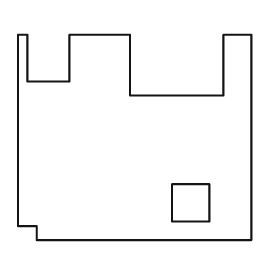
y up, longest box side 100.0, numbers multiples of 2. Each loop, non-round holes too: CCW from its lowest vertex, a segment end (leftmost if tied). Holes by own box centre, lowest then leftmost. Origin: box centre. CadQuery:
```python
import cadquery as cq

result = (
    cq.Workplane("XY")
    .moveTo(-42.0, -44.0)
    .lineTo(50.0, -44.0)
    .lineTo(50.0, 44.0)
    .lineTo(38.0, 44.0)
    .lineTo(38.0, 18.0)
    .lineTo(-2.0, 18.0)
    .lineTo(-2.0, 44.0)
    .lineTo(-28.0, 44.0)
    .lineTo(-28.0, 24.0)
    .lineTo(-46.0, 24.0)
    .lineTo(-46.0, 44.0)
    .lineTo(-50.0, 44.0)
    .lineTo(-50.0, -38.0)
    .lineTo(-42.0, -38.0)
    .close()
    .moveTo(16.0, -36.0)
    .lineTo(32.0, -36.0)
    .lineTo(32.0, -20.0)
    .lineTo(16.0, -20.0)
    .close()
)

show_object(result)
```